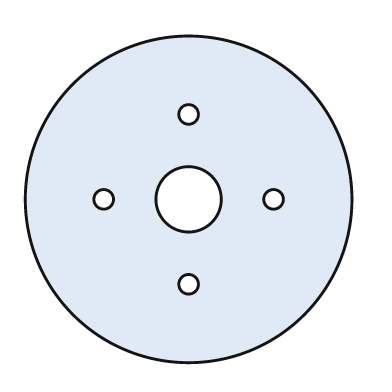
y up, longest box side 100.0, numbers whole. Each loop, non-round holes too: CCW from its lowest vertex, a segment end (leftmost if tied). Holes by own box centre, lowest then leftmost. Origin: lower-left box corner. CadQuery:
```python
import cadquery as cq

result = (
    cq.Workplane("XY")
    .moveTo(50.0, 50.0)
    .circle(50.0)
    .moveTo(50.0, 24.0)
    .circle(3.0)
    .moveTo(24.0, 50.0)
    .circle(3.0)
    .moveTo(50.0, 50.0)
    .circle(10.0)
    .moveTo(76.0, 50.0)
    .circle(3.0)
    .moveTo(50.0, 76.0)
    .circle(3.0)
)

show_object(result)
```